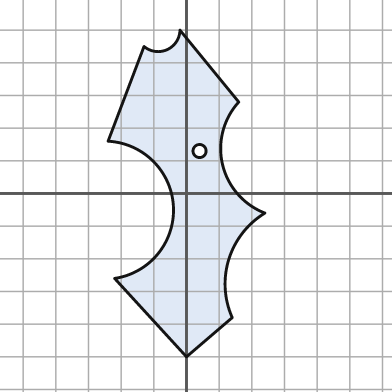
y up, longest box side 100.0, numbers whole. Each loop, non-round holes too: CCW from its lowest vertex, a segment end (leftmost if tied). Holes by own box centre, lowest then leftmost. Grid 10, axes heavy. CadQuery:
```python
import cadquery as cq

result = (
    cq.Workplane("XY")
    .moveTo(0.0, -50.0)
    .lineTo(14.0, -38.0)
    .threePointArc((13.0, -20.0), (24.0, -6.0))
    .threePointArc((11.0, 9.0), (16.0, 28.0))
    .lineTo(-2.0, 50.0)
    .threePointArc((-6.0, 44.0), (-13.0, 45.0))
    .lineTo(-24.0, 16.0)
    .threePointArc((-4.0, -4.0), (-22.0, -26.0))
    .close()
    .moveTo(4.0, 13.0)
    .circle(2.0)
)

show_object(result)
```